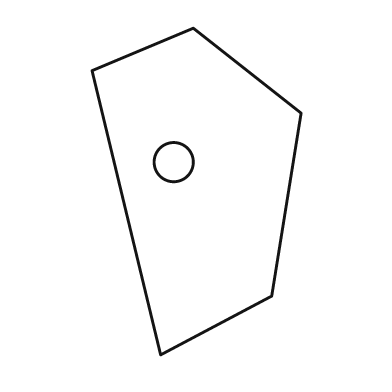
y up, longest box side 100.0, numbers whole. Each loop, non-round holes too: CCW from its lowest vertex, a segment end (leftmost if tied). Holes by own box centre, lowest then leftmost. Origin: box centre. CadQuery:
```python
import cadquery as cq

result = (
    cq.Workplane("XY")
    .moveTo(-11.0, -50.0)
    .lineTo(23.0, -32.0)
    .lineTo(32.0, 24.0)
    .lineTo(-1.0, 50.0)
    .lineTo(-32.0, 37.0)
    .close()
    .moveTo(-7.0, 9.0)
    .circle(6.0)
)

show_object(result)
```